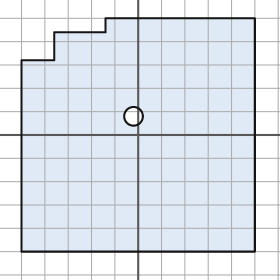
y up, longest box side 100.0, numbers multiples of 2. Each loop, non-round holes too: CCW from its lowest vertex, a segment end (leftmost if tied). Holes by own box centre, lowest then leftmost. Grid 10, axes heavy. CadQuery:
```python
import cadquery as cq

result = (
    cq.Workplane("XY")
    .moveTo(-50.0, -50.0)
    .lineTo(50.0, -50.0)
    .lineTo(50.0, 50.0)
    .lineTo(-14.0, 50.0)
    .lineTo(-14.0, 44.0)
    .lineTo(-36.0, 44.0)
    .lineTo(-36.0, 32.0)
    .lineTo(-50.0, 32.0)
    .close()
    .moveTo(-2.0, 8.0)
    .circle(4.0)
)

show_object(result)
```